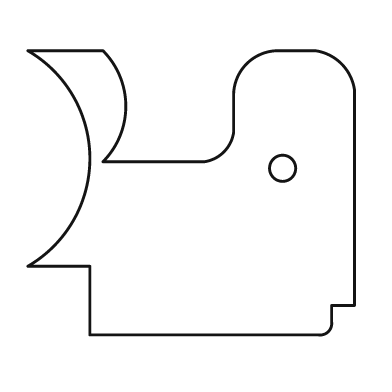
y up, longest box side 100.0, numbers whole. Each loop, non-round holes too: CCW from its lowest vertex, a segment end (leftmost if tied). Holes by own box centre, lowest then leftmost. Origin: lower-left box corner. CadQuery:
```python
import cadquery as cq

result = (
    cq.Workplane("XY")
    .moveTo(19.0, 0.0)
    .lineTo(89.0, 0.0)
    .threePointArc((92.0, 1.0), (93.0, 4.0))
    .lineTo(93.0, 9.0)
    .lineTo(100.0, 9.0)
    .lineTo(100.0, 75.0)
    .threePointArc((96.0, 83.0), (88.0, 87.0))
    .lineTo(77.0, 87.0)
    .threePointArc((67.0, 83.0), (63.0, 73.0))
    .lineTo(63.0, 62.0)
    .threePointArc((60.0, 56.0), (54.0, 53.0))
    .lineTo(23.0, 53.0)
    .threePointArc((30.0, 70.0), (23.0, 87.0))
    .lineTo(0.0, 87.0)
    .threePointArc((19.0, 54.0), (0.0, 21.0))
    .lineTo(19.0, 21.0)
    .close()
    .moveTo(78.0, 51.0)
    .circle(4.0)
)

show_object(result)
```